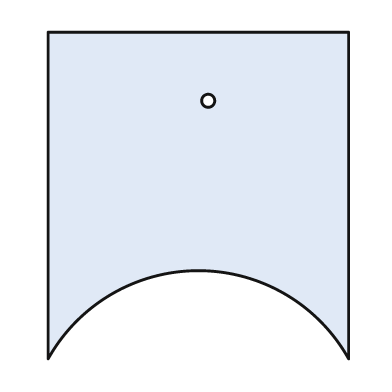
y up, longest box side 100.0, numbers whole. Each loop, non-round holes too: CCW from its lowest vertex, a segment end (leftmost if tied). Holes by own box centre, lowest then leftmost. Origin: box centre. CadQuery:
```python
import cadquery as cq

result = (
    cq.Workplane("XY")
    .moveTo(-46.0, -50.0)
    .threePointArc((0.0, -23.0), (46.0, -50.0))
    .lineTo(46.0, 50.0)
    .lineTo(-46.0, 50.0)
    .close()
    .moveTo(3.0, 29.0)
    .circle(2.0)
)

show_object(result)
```